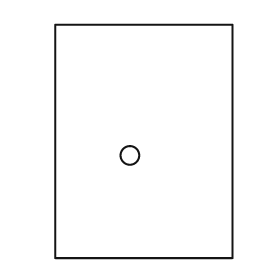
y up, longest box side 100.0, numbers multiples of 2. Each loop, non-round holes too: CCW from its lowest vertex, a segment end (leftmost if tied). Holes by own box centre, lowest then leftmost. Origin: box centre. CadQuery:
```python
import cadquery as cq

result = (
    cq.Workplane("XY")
    .moveTo(-38.0, -50.0)
    .lineTo(38.0, -50.0)
    .lineTo(38.0, 50.0)
    .lineTo(-38.0, 50.0)
    .close()
    .moveTo(-6.0, -6.0)
    .circle(4.0)
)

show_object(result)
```